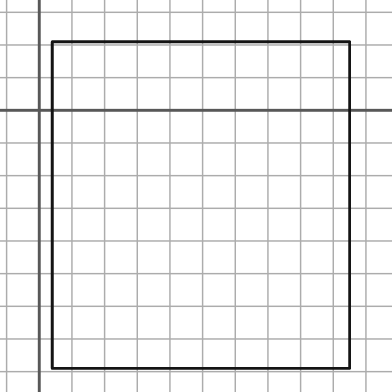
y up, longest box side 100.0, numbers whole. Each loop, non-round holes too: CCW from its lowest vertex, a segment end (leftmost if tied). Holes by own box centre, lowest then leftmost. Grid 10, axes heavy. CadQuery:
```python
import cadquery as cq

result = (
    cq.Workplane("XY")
    .moveTo(4.0, -79.0)
    .lineTo(95.0, -79.0)
    .lineTo(95.0, 21.0)
    .lineTo(4.0, 21.0)
    .close()
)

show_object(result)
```